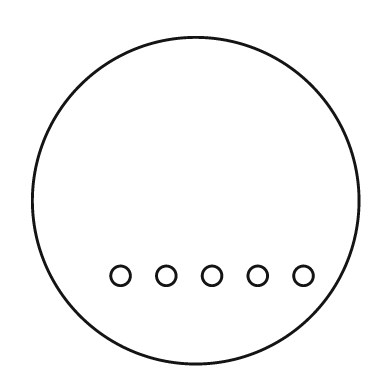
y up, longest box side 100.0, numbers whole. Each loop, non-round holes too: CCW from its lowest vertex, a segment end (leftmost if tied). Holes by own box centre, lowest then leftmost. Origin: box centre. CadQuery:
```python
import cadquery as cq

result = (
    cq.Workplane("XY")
    .moveTo(0.0, 0.0)
    .circle(50.0)
    .moveTo(-23.0, -23.0)
    .circle(3.0)
    .moveTo(-9.0, -23.0)
    .circle(3.0)
    .moveTo(5.0, -23.0)
    .circle(3.0)
    .moveTo(19.0, -23.0)
    .circle(3.0)
    .moveTo(33.0, -23.0)
    .circle(3.0)
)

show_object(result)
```